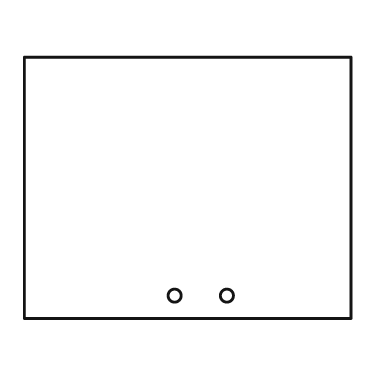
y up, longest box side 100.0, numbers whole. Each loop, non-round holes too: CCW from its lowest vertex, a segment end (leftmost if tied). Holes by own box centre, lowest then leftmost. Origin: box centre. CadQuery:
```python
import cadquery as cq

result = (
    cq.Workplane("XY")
    .moveTo(-50.0, -40.0)
    .lineTo(50.0, -40.0)
    .lineTo(50.0, 40.0)
    .lineTo(-50.0, 40.0)
    .close()
    .moveTo(-4.0, -33.0)
    .circle(2.0)
    .moveTo(12.0, -33.0)
    .circle(2.0)
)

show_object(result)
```